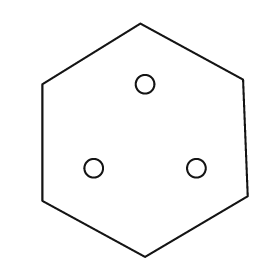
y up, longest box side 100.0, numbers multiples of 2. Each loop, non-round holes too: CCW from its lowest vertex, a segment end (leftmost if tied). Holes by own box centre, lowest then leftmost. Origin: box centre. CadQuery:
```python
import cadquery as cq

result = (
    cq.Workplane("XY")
    .moveTo(0.0, -50.0)
    .lineTo(44.0, -24.0)
    .lineTo(42.0, 26.0)
    .lineTo(-2.0, 50.0)
    .lineTo(-44.0, 24.0)
    .lineTo(-44.0, -26.0)
    .close()
    .moveTo(-22.0, -12.0)
    .circle(4.0)
    .moveTo(22.0, -12.0)
    .circle(4.0)
    .moveTo(0.0, 24.0)
    .circle(4.0)
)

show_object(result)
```